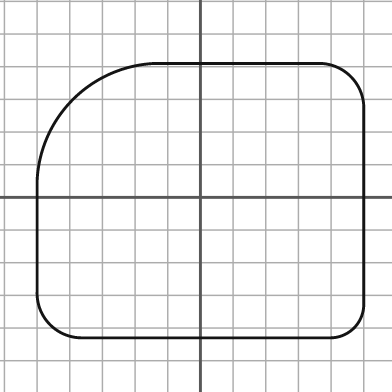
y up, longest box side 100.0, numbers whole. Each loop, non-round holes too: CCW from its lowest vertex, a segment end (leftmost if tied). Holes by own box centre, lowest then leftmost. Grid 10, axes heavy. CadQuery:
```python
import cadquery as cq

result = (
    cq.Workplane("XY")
    .moveTo(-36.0, -43.0)
    .lineTo(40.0, -43.0)
    .threePointArc((47.0, -40.0), (50.0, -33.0))
    .lineTo(50.0, 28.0)
    .threePointArc((46.0, 37.0), (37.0, 41.0))
    .lineTo(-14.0, 41.0)
    .threePointArc((-39.0, 30.0), (-50.0, 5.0))
    .lineTo(-50.0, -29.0)
    .threePointArc((-46.0, -39.0), (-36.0, -43.0))
    .close()
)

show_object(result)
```